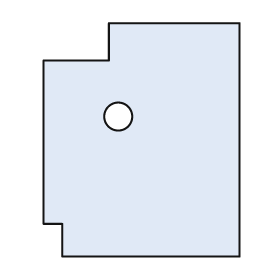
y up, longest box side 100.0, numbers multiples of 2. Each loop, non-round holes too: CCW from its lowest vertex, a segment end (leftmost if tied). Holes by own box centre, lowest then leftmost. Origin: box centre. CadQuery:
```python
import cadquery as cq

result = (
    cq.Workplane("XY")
    .moveTo(-34.0, -50.0)
    .lineTo(42.0, -50.0)
    .lineTo(42.0, 50.0)
    .lineTo(-14.0, 50.0)
    .lineTo(-14.0, 34.0)
    .lineTo(-42.0, 34.0)
    .lineTo(-42.0, -36.0)
    .lineTo(-34.0, -36.0)
    .close()
    .moveTo(-10.0, 10.0)
    .circle(6.0)
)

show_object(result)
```